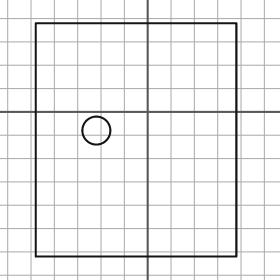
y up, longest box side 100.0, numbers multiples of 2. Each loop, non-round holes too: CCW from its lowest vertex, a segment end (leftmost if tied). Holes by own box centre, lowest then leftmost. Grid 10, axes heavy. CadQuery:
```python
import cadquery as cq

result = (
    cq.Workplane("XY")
    .moveTo(-48.0, -62.0)
    .lineTo(38.0, -62.0)
    .lineTo(38.0, 38.0)
    .lineTo(-48.0, 38.0)
    .close()
    .moveTo(-22.0, -8.0)
    .circle(6.0)
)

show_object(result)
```